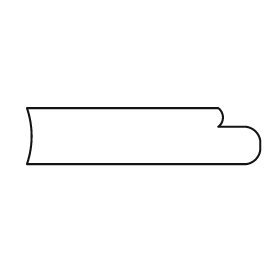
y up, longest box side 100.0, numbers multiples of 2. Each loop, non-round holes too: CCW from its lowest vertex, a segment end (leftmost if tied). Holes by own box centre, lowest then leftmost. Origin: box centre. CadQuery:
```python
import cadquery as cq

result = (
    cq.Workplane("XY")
    .moveTo(-50.0, -12.0)
    .lineTo(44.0, -12.0)
    .threePointArc((48.0, -10.0), (50.0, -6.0))
    .lineTo(50.0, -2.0)
    .threePointArc((48.0, 2.0), (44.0, 4.0))
    .lineTo(32.0, 4.0)
    .threePointArc((34.0, 8.0), (32.0, 12.0))
    .lineTo(-50.0, 12.0)
    .threePointArc((-48.0, 0.0), (-50.0, -12.0))
    .close()
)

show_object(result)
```